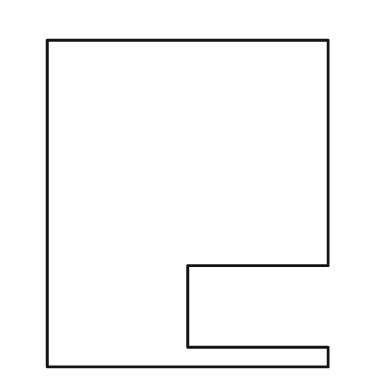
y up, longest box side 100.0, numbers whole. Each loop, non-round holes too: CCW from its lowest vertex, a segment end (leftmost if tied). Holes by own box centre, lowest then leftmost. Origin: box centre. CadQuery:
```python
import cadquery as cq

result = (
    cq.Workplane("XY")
    .moveTo(-43.0, -50.0)
    .lineTo(43.0, -50.0)
    .lineTo(43.0, -44.0)
    .lineTo(0.0, -44.0)
    .lineTo(0.0, -19.0)
    .lineTo(43.0, -19.0)
    .lineTo(43.0, 50.0)
    .lineTo(-43.0, 50.0)
    .close()
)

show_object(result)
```